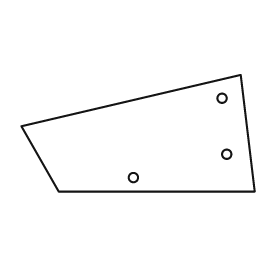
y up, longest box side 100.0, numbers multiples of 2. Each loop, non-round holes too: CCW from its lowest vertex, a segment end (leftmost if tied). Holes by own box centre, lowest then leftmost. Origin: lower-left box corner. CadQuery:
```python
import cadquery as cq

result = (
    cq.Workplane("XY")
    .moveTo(16.0, 0.0)
    .lineTo(100.0, 0.0)
    .lineTo(94.0, 50.0)
    .lineTo(0.0, 28.0)
    .close()
    .moveTo(48.0, 6.0)
    .circle(2.0)
    .moveTo(88.0, 16.0)
    .circle(2.0)
    .moveTo(86.0, 40.0)
    .circle(2.0)
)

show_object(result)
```